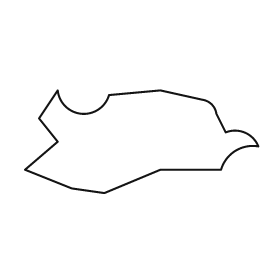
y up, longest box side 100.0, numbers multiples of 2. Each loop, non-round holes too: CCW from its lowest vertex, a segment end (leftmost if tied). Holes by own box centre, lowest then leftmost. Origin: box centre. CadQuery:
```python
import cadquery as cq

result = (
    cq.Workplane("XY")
    .moveTo(-16.0, -22.0)
    .lineTo(8.0, -12.0)
    .lineTo(34.0, -12.0)
    .threePointArc((40.0, -4.0), (50.0, -2.0))
    .threePointArc((44.0, 4.0), (36.0, 4.0))
    .lineTo(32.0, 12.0)
    .threePointArc((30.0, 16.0), (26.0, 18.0))
    .lineTo(8.0, 22.0)
    .lineTo(-14.0, 20.0)
    .threePointArc((-26.0, 12.0), (-36.0, 22.0))
    .lineTo(-44.0, 10.0)
    .lineTo(-36.0, 0.0)
    .lineTo(-50.0, -12.0)
    .lineTo(-30.0, -20.0)
    .close()
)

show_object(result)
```